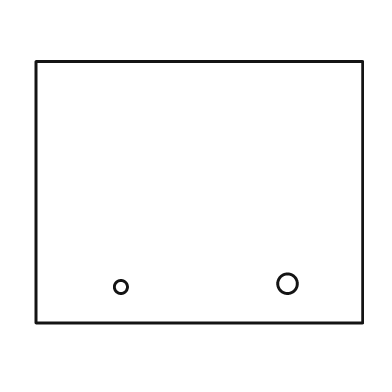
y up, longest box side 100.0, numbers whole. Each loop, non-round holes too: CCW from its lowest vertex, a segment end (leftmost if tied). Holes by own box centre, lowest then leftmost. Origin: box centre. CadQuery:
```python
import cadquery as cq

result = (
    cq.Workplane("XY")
    .moveTo(-50.0, -40.0)
    .lineTo(50.0, -40.0)
    .lineTo(50.0, 40.0)
    .lineTo(-50.0, 40.0)
    .close()
    .moveTo(-24.0, -29.0)
    .circle(2.0)
    .moveTo(27.0, -28.0)
    .circle(3.0)
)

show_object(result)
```